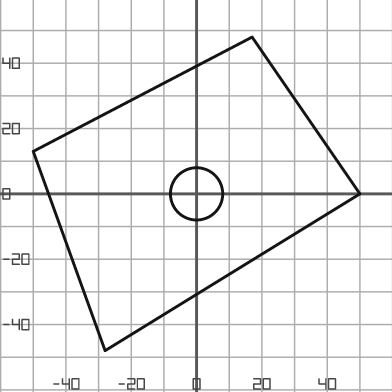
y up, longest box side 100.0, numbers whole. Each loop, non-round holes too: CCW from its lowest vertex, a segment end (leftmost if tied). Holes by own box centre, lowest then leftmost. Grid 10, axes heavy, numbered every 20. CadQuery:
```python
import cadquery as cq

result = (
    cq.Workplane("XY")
    .moveTo(-28.0, -48.0)
    .lineTo(50.0, 0.0)
    .lineTo(17.0, 48.0)
    .lineTo(-50.0, 13.0)
    .close()
    .moveTo(0.0, 0.0)
    .circle(8.0)
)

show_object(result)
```